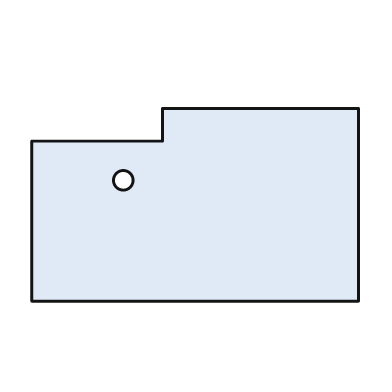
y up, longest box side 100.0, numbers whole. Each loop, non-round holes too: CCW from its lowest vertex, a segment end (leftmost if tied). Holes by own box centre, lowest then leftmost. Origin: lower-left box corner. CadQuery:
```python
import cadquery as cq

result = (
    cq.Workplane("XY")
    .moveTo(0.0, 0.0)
    .lineTo(100.0, 0.0)
    .lineTo(100.0, 59.0)
    .lineTo(40.0, 59.0)
    .lineTo(40.0, 49.0)
    .lineTo(0.0, 49.0)
    .close()
    .moveTo(28.0, 37.0)
    .circle(3.0)
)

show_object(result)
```